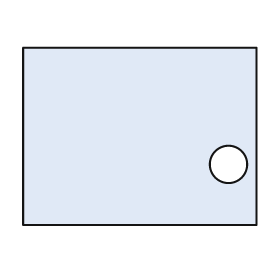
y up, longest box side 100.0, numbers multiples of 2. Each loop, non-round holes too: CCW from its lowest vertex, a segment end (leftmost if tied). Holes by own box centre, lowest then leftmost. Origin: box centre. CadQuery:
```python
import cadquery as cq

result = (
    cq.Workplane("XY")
    .moveTo(-50.0, -38.0)
    .lineTo(50.0, -38.0)
    .lineTo(50.0, 38.0)
    .lineTo(-50.0, 38.0)
    .close()
    .moveTo(38.0, -12.0)
    .circle(8.0)
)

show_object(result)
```